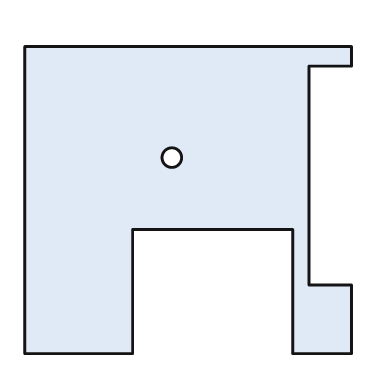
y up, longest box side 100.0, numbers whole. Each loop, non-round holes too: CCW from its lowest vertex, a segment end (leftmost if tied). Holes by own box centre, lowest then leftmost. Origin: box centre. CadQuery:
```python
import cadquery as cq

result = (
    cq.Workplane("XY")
    .moveTo(-50.0, -47.0)
    .lineTo(-17.0, -47.0)
    .lineTo(-17.0, -9.0)
    .lineTo(32.0, -9.0)
    .lineTo(32.0, -47.0)
    .lineTo(50.0, -47.0)
    .lineTo(50.0, -26.0)
    .lineTo(37.0, -26.0)
    .lineTo(37.0, 41.0)
    .lineTo(50.0, 41.0)
    .lineTo(50.0, 47.0)
    .lineTo(-50.0, 47.0)
    .close()
    .moveTo(-5.0, 13.0)
    .circle(3.0)
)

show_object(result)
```